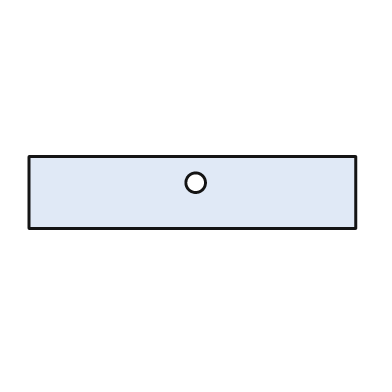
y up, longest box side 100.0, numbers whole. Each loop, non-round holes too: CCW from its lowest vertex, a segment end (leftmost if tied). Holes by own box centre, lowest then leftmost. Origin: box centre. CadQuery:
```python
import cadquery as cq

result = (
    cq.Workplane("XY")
    .moveTo(-50.0, -11.0)
    .lineTo(50.0, -11.0)
    .lineTo(50.0, 11.0)
    .lineTo(-50.0, 11.0)
    .close()
    .moveTo(1.0, 3.0)
    .circle(3.0)
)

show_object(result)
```